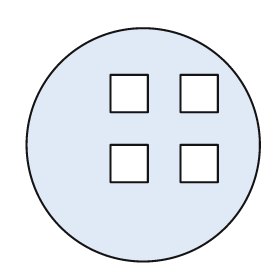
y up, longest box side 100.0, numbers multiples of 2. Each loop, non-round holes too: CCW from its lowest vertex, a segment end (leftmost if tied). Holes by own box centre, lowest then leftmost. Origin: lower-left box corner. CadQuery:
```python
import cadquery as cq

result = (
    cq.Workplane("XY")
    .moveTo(50.0, 50.0)
    .circle(50.0)
    .moveTo(36.0, 34.0)
    .lineTo(52.0, 34.0)
    .lineTo(52.0, 50.0)
    .lineTo(36.0, 50.0)
    .close()
    .moveTo(66.0, 34.0)
    .lineTo(82.0, 34.0)
    .lineTo(82.0, 50.0)
    .lineTo(66.0, 50.0)
    .close()
    .moveTo(36.0, 64.0)
    .lineTo(52.0, 64.0)
    .lineTo(52.0, 80.0)
    .lineTo(36.0, 80.0)
    .close()
    .moveTo(66.0, 64.0)
    .lineTo(82.0, 64.0)
    .lineTo(82.0, 80.0)
    .lineTo(66.0, 80.0)
    .close()
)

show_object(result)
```